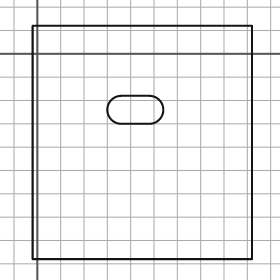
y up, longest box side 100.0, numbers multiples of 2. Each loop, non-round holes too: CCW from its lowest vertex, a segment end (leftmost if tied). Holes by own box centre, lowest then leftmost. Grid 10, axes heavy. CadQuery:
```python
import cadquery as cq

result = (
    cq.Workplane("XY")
    .moveTo(-2.0, -88.0)
    .lineTo(92.0, -88.0)
    .lineTo(92.0, 12.0)
    .lineTo(-2.0, 12.0)
    .close()
    .moveTo(36.0, -30.0)
    .lineTo(48.0, -30.0)
    .threePointArc((54.0, -24.0), (48.0, -18.0))
    .lineTo(36.0, -18.0)
    .threePointArc((30.0, -24.0), (36.0, -30.0))
    .close()
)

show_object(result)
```